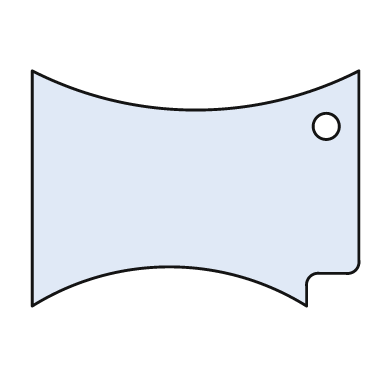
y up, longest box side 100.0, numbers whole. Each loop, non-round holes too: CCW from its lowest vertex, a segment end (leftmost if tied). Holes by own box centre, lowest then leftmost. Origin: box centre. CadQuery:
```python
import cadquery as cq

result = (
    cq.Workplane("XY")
    .moveTo(-50.0, -36.0)
    .threePointArc((-8.0, -24.0), (34.0, -36.0))
    .lineTo(34.0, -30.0)
    .threePointArc((35.0, -27.0), (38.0, -26.0))
    .lineTo(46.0, -26.0)
    .threePointArc((49.0, -25.0), (50.0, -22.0))
    .lineTo(50.0, 36.0)
    .threePointArc((0.0, 24.0), (-50.0, 36.0))
    .close()
    .moveTo(40.0, 19.0)
    .circle(4.0)
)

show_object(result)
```